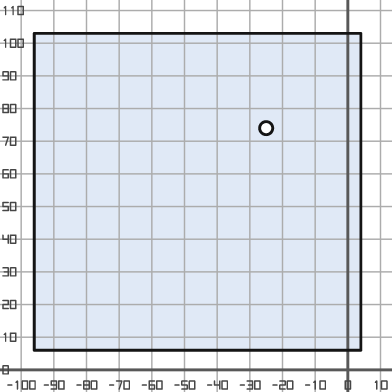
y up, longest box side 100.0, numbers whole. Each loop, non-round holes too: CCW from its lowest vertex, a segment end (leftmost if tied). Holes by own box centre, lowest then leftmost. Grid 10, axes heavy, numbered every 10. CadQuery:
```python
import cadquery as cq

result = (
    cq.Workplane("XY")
    .moveTo(-96.0, 6.0)
    .lineTo(4.0, 6.0)
    .lineTo(4.0, 103.0)
    .lineTo(-96.0, 103.0)
    .close()
    .moveTo(-25.0, 74.0)
    .circle(2.0)
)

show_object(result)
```